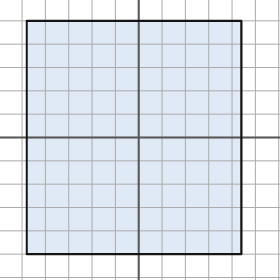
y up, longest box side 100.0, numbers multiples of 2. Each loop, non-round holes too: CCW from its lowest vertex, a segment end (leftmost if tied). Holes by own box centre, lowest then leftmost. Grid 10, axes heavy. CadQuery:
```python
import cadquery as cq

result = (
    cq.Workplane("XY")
    .moveTo(-48.0, -50.0)
    .lineTo(44.0, -50.0)
    .lineTo(44.0, 50.0)
    .lineTo(-48.0, 50.0)
    .close()
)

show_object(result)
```